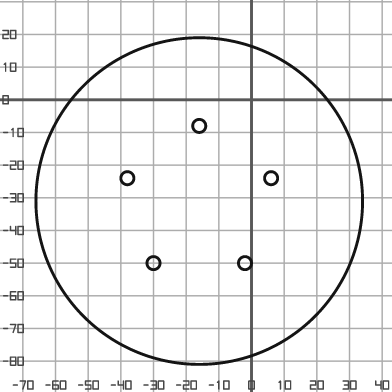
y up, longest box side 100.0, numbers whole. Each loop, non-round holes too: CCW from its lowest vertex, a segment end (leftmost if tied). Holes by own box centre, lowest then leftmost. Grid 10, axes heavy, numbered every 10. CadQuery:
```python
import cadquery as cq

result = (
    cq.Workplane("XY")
    .moveTo(-16.0, -31.0)
    .circle(50.0)
    .moveTo(-30.0, -50.0)
    .circle(2.0)
    .moveTo(-2.0, -50.0)
    .circle(2.0)
    .moveTo(-38.0, -24.0)
    .circle(2.0)
    .moveTo(6.0, -24.0)
    .circle(2.0)
    .moveTo(-16.0, -8.0)
    .circle(2.0)
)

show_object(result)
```